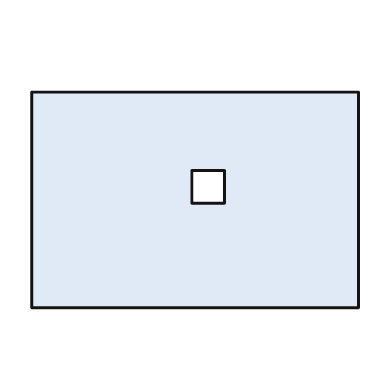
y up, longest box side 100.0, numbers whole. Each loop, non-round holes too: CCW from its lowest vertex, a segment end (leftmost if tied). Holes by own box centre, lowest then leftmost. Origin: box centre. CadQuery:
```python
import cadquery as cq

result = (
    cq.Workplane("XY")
    .moveTo(-50.0, -33.0)
    .lineTo(50.0, -33.0)
    .lineTo(50.0, 33.0)
    .lineTo(-50.0, 33.0)
    .close()
    .moveTo(-1.0, -1.0)
    .lineTo(9.0, -1.0)
    .lineTo(9.0, 9.0)
    .lineTo(-1.0, 9.0)
    .close()
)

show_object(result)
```